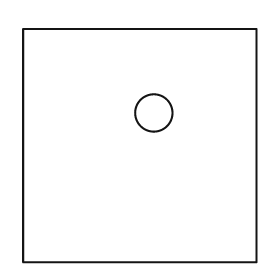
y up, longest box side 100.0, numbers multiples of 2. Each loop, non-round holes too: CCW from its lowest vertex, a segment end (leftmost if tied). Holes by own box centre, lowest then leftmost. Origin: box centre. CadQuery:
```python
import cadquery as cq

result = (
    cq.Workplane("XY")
    .moveTo(-50.0, -50.0)
    .lineTo(50.0, -50.0)
    .lineTo(50.0, 50.0)
    .lineTo(-50.0, 50.0)
    .close()
    .moveTo(6.0, 14.0)
    .circle(8.0)
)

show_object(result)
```